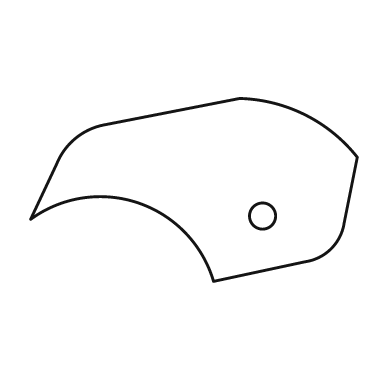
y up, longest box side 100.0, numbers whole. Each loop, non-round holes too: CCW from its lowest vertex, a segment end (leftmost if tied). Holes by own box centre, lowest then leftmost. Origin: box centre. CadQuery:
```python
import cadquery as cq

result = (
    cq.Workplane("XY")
    .moveTo(6.0, -28.0)
    .lineTo(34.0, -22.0)
    .threePointArc((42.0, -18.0), (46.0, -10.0))
    .lineTo(50.0, 10.0)
    .threePointArc((34.0, 23.0), (14.0, 28.0))
    .lineTo(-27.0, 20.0)
    .threePointArc((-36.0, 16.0), (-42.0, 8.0))
    .lineTo(-50.0, -9.0)
    .threePointArc((-17.0, -4.0), (6.0, -28.0))
    .close()
    .moveTo(21.0, -8.0)
    .circle(4.0)
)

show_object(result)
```